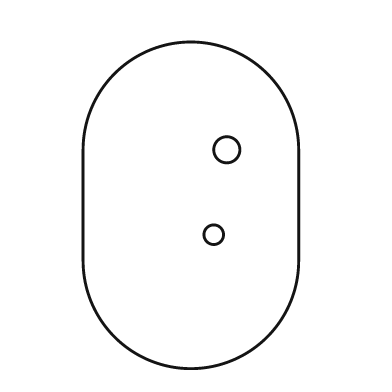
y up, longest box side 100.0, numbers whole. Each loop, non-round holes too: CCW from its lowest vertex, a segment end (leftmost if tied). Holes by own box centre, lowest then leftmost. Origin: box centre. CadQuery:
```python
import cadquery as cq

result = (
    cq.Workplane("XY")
    .moveTo(-33.0, -17.0)
    .threePointArc((0.0, -50.0), (33.0, -17.0))
    .lineTo(33.0, 17.0)
    .threePointArc((0.0, 50.0), (-33.0, 17.0))
    .close()
    .moveTo(7.0, -9.0)
    .circle(3.0)
    .moveTo(11.0, 17.0)
    .circle(4.0)
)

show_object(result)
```